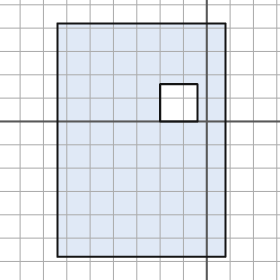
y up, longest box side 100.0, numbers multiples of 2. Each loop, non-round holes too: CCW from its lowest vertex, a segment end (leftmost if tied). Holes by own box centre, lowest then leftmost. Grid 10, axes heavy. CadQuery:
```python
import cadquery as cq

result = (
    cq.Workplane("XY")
    .moveTo(-64.0, -58.0)
    .lineTo(8.0, -58.0)
    .lineTo(8.0, 42.0)
    .lineTo(-64.0, 42.0)
    .close()
    .moveTo(-20.0, 0.0)
    .lineTo(-4.0, 0.0)
    .lineTo(-4.0, 16.0)
    .lineTo(-20.0, 16.0)
    .close()
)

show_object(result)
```